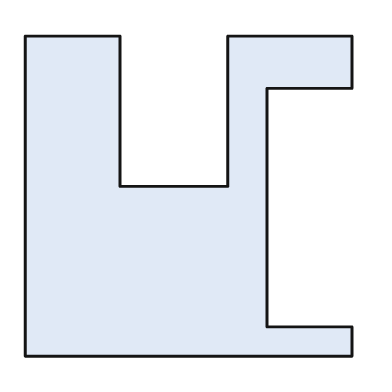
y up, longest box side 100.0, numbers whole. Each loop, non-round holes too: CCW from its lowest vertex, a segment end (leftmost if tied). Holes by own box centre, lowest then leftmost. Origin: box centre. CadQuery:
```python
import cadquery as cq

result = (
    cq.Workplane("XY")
    .moveTo(-50.0, -49.0)
    .lineTo(50.0, -49.0)
    .lineTo(50.0, -40.0)
    .lineTo(24.0, -40.0)
    .lineTo(24.0, 33.0)
    .lineTo(50.0, 33.0)
    .lineTo(50.0, 49.0)
    .lineTo(12.0, 49.0)
    .lineTo(12.0, 3.0)
    .lineTo(-21.0, 3.0)
    .lineTo(-21.0, 49.0)
    .lineTo(-50.0, 49.0)
    .close()
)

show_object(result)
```